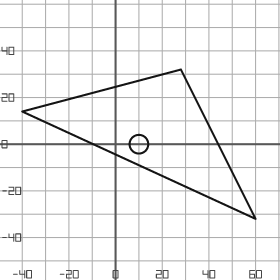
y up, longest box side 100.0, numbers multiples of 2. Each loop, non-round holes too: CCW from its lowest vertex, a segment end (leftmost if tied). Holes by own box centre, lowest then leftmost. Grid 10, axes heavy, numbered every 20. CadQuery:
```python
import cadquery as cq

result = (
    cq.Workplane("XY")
    .moveTo(60.0, -32.0)
    .lineTo(28.0, 32.0)
    .lineTo(-40.0, 14.0)
    .close()
    .moveTo(10.0, 0.0)
    .circle(4.0)
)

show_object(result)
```